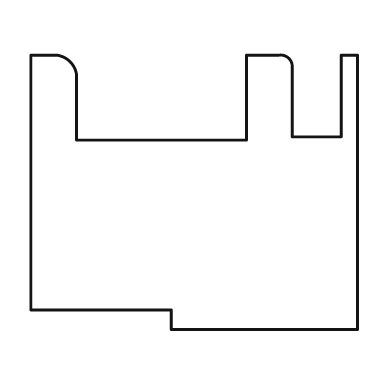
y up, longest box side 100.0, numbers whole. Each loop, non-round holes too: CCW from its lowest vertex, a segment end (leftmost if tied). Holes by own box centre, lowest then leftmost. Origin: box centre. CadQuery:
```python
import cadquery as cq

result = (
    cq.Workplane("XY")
    .moveTo(-7.0, -42.0)
    .lineTo(50.0, -42.0)
    .lineTo(50.0, 42.0)
    .lineTo(45.0, 42.0)
    .lineTo(45.0, 17.0)
    .lineTo(30.0, 17.0)
    .lineTo(30.0, 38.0)
    .threePointArc((29.0, 41.0), (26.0, 42.0))
    .lineTo(16.0, 42.0)
    .lineTo(16.0, 16.0)
    .lineTo(-36.0, 16.0)
    .lineTo(-36.0, 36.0)
    .threePointArc((-38.0, 40.0), (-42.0, 42.0))
    .lineTo(-50.0, 42.0)
    .lineTo(-50.0, -36.0)
    .lineTo(-7.0, -36.0)
    .close()
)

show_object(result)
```